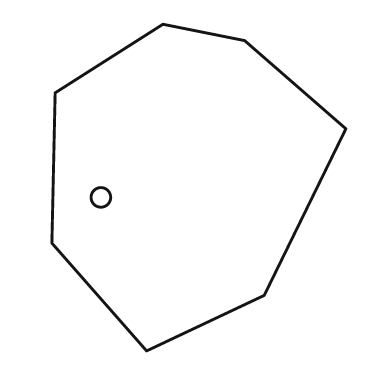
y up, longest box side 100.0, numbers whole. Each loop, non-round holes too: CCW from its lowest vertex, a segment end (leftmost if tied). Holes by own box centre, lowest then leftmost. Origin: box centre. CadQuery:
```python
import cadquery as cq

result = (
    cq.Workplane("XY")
    .moveTo(-16.0, -50.0)
    .lineTo(20.0, -33.0)
    .lineTo(45.0, 18.0)
    .lineTo(14.0, 45.0)
    .lineTo(-11.0, 50.0)
    .lineTo(-44.0, 29.0)
    .lineTo(-45.0, -17.0)
    .close()
    .moveTo(-30.0, -3.0)
    .circle(3.0)
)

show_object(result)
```